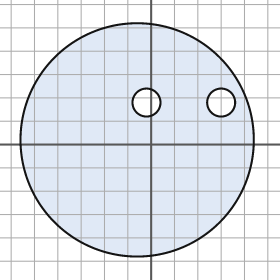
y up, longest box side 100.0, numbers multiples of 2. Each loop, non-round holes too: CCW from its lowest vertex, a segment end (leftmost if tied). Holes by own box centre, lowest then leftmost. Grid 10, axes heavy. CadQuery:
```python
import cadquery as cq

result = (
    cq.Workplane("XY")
    .moveTo(-6.0, 2.0)
    .circle(50.0)
    .moveTo(-2.0, 18.0)
    .circle(6.0)
    .moveTo(30.0, 18.0)
    .circle(6.0)
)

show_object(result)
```